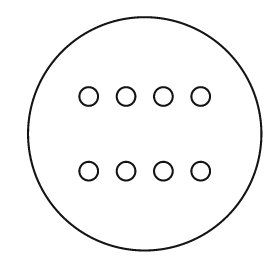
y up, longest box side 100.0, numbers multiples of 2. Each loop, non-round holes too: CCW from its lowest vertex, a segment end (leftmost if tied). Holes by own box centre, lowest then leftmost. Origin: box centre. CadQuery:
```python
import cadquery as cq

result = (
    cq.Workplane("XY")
    .moveTo(0.0, 0.0)
    .circle(50.0)
    .moveTo(-24.0, -16.0)
    .circle(4.0)
    .moveTo(-8.0, -16.0)
    .circle(4.0)
    .moveTo(8.0, -16.0)
    .circle(4.0)
    .moveTo(24.0, -16.0)
    .circle(4.0)
    .moveTo(-24.0, 16.0)
    .circle(4.0)
    .moveTo(-8.0, 16.0)
    .circle(4.0)
    .moveTo(8.0, 16.0)
    .circle(4.0)
    .moveTo(24.0, 16.0)
    .circle(4.0)
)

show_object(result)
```